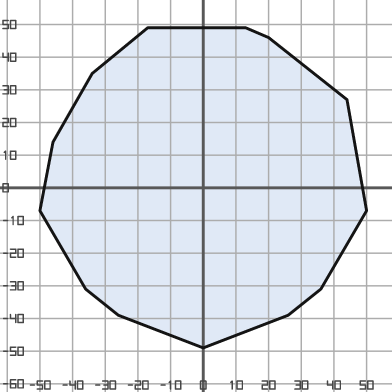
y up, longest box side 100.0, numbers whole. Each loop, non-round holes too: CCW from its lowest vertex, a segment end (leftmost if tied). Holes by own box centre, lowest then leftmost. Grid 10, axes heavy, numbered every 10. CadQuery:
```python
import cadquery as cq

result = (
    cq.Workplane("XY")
    .moveTo(0.0, -49.0)
    .lineTo(26.0, -39.0)
    .lineTo(36.0, -31.0)
    .lineTo(50.0, -7.0)
    .lineTo(44.0, 27.0)
    .lineTo(20.0, 46.0)
    .lineTo(13.0, 49.0)
    .lineTo(-17.0, 49.0)
    .lineTo(-34.0, 35.0)
    .lineTo(-46.0, 14.0)
    .lineTo(-50.0, -7.0)
    .lineTo(-36.0, -31.0)
    .lineTo(-26.0, -39.0)
    .close()
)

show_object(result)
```